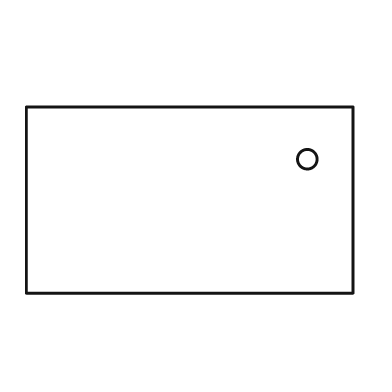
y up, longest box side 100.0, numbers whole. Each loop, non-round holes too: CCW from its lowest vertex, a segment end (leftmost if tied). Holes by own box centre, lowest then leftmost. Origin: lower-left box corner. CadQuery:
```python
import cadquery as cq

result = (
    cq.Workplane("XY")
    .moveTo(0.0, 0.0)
    .lineTo(100.0, 0.0)
    .lineTo(100.0, 57.0)
    .lineTo(0.0, 57.0)
    .close()
    .moveTo(86.0, 41.0)
    .circle(3.0)
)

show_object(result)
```